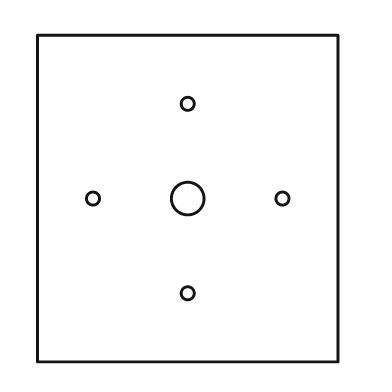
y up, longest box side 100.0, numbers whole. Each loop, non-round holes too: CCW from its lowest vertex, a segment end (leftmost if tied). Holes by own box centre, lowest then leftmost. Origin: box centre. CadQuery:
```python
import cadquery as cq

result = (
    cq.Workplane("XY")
    .moveTo(-46.0, -50.0)
    .lineTo(46.0, -50.0)
    .lineTo(46.0, 50.0)
    .lineTo(-46.0, 50.0)
    .close()
    .moveTo(0.0, -29.0)
    .circle(2.0)
    .moveTo(-29.0, 0.0)
    .circle(2.0)
    .moveTo(0.0, 0.0)
    .circle(5.0)
    .moveTo(29.0, 0.0)
    .circle(2.0)
    .moveTo(0.0, 29.0)
    .circle(2.0)
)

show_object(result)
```